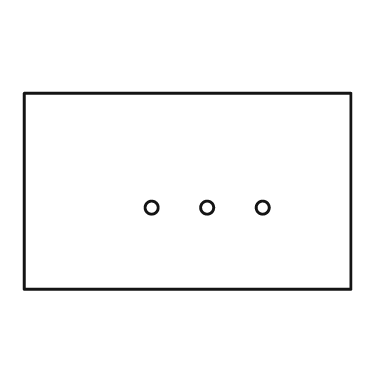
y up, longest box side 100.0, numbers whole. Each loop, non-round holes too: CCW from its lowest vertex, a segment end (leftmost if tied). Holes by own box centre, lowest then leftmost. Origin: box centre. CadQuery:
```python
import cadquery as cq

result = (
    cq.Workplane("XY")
    .moveTo(-50.0, -30.0)
    .lineTo(50.0, -30.0)
    .lineTo(50.0, 30.0)
    .lineTo(-50.0, 30.0)
    .close()
    .moveTo(-11.0, -5.0)
    .circle(2.0)
    .moveTo(6.0, -5.0)
    .circle(2.0)
    .moveTo(23.0, -5.0)
    .circle(2.0)
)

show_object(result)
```